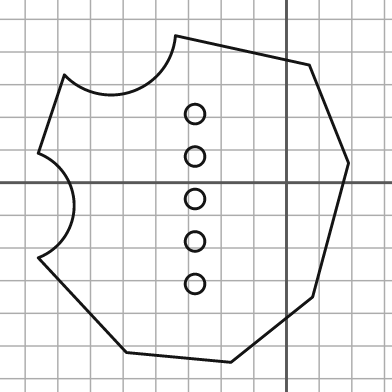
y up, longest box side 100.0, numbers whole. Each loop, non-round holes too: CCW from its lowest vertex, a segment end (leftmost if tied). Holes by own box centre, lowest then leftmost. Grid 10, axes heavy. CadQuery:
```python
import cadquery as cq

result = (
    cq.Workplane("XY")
    .moveTo(-17.0, -55.0)
    .lineTo(8.0, -35.0)
    .lineTo(19.0, 6.0)
    .lineTo(7.0, 36.0)
    .lineTo(-34.0, 45.0)
    .threePointArc((-47.0, 28.0), (-68.0, 33.0))
    .lineTo(-76.0, 9.0)
    .threePointArc((-65.0, -7.0), (-76.0, -23.0))
    .lineTo(-49.0, -52.0)
    .close()
    .moveTo(-28.0, -31.0)
    .circle(3.0)
    .moveTo(-28.0, -18.0)
    .circle(3.0)
    .moveTo(-28.0, -5.0)
    .circle(3.0)
    .moveTo(-28.0, 8.0)
    .circle(3.0)
    .moveTo(-28.0, 21.0)
    .circle(3.0)
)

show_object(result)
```